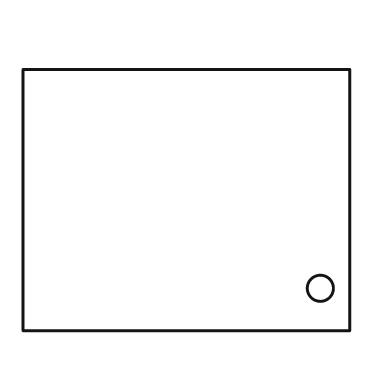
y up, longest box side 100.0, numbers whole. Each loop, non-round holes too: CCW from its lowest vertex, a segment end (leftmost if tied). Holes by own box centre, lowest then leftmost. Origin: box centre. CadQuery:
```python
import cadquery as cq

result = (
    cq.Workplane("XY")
    .moveTo(-50.0, -40.0)
    .lineTo(50.0, -40.0)
    .lineTo(50.0, 40.0)
    .lineTo(-50.0, 40.0)
    .close()
    .moveTo(41.0, -27.0)
    .circle(4.0)
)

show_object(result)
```